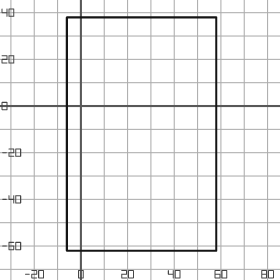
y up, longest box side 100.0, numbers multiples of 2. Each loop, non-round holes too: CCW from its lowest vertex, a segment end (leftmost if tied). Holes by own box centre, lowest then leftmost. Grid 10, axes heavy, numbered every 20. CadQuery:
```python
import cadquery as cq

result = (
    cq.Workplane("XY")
    .moveTo(-6.0, -62.0)
    .lineTo(58.0, -62.0)
    .lineTo(58.0, 38.0)
    .lineTo(-6.0, 38.0)
    .close()
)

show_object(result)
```